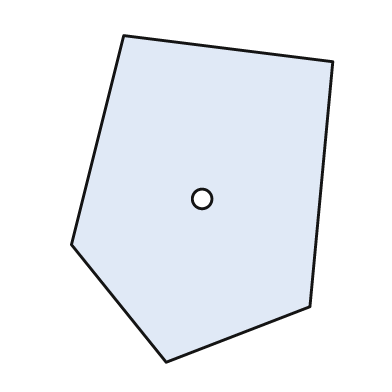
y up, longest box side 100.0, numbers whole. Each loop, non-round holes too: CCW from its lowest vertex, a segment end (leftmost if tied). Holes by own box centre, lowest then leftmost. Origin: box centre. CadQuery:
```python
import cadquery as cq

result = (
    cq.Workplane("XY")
    .moveTo(-11.0, -50.0)
    .lineTo(33.0, -33.0)
    .lineTo(40.0, 42.0)
    .lineTo(-24.0, 50.0)
    .lineTo(-40.0, -14.0)
    .close()
    .moveTo(0.0, 0.0)
    .circle(3.0)
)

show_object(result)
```